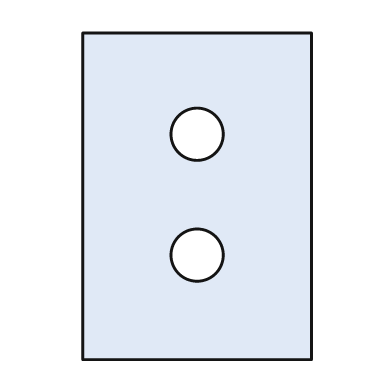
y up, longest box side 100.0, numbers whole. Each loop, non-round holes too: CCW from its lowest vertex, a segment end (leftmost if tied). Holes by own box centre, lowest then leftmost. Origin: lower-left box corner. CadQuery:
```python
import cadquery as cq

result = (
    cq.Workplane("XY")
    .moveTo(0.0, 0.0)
    .lineTo(70.0, 0.0)
    .lineTo(70.0, 100.0)
    .lineTo(0.0, 100.0)
    .close()
    .moveTo(35.0, 32.0)
    .circle(8.0)
    .moveTo(35.0, 69.0)
    .circle(8.0)
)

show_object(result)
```